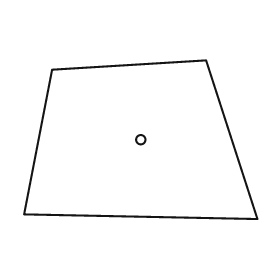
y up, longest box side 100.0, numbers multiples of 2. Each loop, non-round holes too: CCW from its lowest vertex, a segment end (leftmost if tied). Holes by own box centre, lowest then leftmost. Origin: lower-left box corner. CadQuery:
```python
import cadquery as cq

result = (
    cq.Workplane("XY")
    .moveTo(100.0, 0.0)
    .lineTo(78.0, 68.0)
    .lineTo(12.0, 64.0)
    .lineTo(0.0, 2.0)
    .close()
    .moveTo(50.0, 34.0)
    .circle(2.0)
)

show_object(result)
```